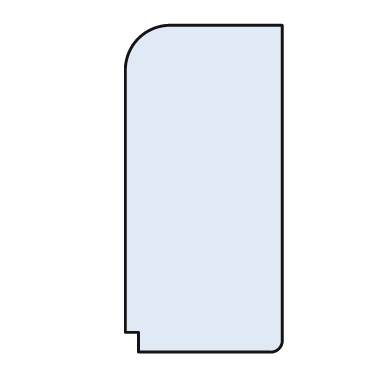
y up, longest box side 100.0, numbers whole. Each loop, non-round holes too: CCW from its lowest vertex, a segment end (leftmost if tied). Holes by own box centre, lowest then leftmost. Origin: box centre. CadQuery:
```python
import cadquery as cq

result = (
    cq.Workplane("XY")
    .moveTo(-20.0, -50.0)
    .lineTo(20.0, -50.0)
    .threePointArc((23.0, -49.0), (24.0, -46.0))
    .lineTo(24.0, 50.0)
    .lineTo(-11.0, 50.0)
    .threePointArc((-20.0, 46.0), (-24.0, 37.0))
    .lineTo(-24.0, -44.0)
    .lineTo(-20.0, -44.0)
    .close()
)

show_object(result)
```